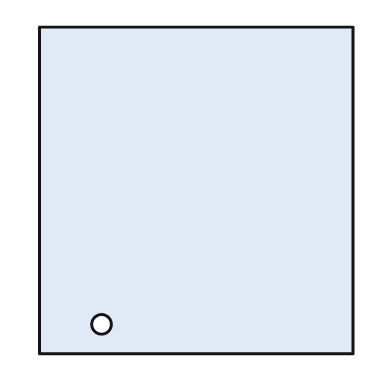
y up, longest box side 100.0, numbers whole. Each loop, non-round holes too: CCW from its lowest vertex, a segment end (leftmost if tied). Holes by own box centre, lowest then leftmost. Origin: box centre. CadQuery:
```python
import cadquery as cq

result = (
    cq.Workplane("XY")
    .moveTo(-48.0, -50.0)
    .lineTo(48.0, -50.0)
    .lineTo(48.0, 50.0)
    .lineTo(-48.0, 50.0)
    .close()
    .moveTo(-29.0, -41.0)
    .circle(3.0)
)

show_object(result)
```